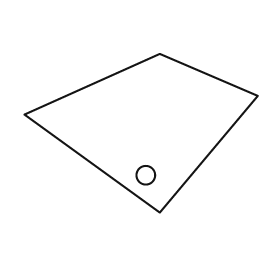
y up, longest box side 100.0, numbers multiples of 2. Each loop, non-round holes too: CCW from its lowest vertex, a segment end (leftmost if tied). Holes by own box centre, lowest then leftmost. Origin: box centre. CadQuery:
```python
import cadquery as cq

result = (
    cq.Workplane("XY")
    .moveTo(8.0, -34.0)
    .lineTo(50.0, 16.0)
    .lineTo(8.0, 34.0)
    .lineTo(-50.0, 8.0)
    .close()
    .moveTo(2.0, -18.0)
    .circle(4.0)
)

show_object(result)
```